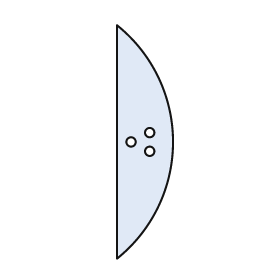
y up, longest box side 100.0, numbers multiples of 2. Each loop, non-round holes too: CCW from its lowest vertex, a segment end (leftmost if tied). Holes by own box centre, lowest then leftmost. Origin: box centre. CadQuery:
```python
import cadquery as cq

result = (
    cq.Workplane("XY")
    .moveTo(-12.0, -50.0)
    .threePointArc((12.0, 0.0), (-12.0, 50.0))
    .close()
    .moveTo(2.0, -4.0)
    .circle(2.0)
    .moveTo(-6.0, 0.0)
    .circle(2.0)
    .moveTo(2.0, 4.0)
    .circle(2.0)
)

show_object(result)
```